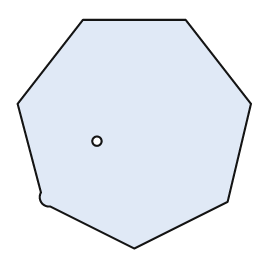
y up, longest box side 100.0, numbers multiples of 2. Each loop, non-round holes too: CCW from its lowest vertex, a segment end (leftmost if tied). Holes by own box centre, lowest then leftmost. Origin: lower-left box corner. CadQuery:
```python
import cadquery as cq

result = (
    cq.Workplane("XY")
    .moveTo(50.0, 0.0)
    .lineTo(90.0, 20.0)
    .lineTo(100.0, 62.0)
    .lineTo(72.0, 98.0)
    .lineTo(28.0, 98.0)
    .lineTo(0.0, 62.0)
    .lineTo(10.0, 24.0)
    .threePointArc((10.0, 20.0), (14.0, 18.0))
    .close()
    .moveTo(34.0, 46.0)
    .circle(2.0)
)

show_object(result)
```